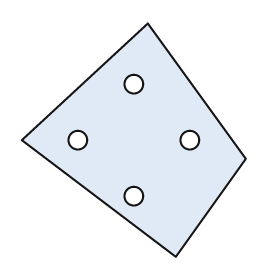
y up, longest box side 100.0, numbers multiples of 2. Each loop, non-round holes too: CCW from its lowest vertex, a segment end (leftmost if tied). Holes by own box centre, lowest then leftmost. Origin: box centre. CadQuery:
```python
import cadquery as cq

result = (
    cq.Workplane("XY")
    .moveTo(18.0, -50.0)
    .lineTo(48.0, -8.0)
    .lineTo(6.0, 50.0)
    .lineTo(-48.0, 0.0)
    .close()
    .moveTo(0.0, -24.0)
    .circle(4.0)
    .moveTo(-24.0, 0.0)
    .circle(4.0)
    .moveTo(24.0, 0.0)
    .circle(4.0)
    .moveTo(0.0, 24.0)
    .circle(4.0)
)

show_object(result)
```